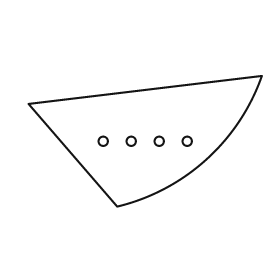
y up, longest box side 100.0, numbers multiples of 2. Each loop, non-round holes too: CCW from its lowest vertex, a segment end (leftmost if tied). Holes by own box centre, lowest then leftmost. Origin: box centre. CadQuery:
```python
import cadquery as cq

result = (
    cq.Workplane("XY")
    .moveTo(-12.0, -28.0)
    .threePointArc((26.0, -8.0), (50.0, 28.0))
    .lineTo(-50.0, 16.0)
    .close()
    .moveTo(-18.0, 0.0)
    .circle(2.0)
    .moveTo(-6.0, 0.0)
    .circle(2.0)
    .moveTo(6.0, 0.0)
    .circle(2.0)
    .moveTo(18.0, 0.0)
    .circle(2.0)
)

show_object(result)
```